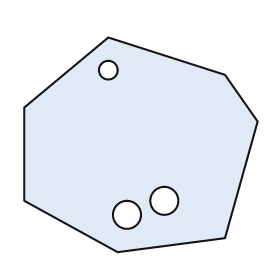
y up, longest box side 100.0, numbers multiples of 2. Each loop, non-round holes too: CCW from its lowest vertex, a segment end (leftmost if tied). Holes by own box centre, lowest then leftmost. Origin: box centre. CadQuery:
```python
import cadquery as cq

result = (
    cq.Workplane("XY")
    .moveTo(-10.0, -46.0)
    .lineTo(36.0, -40.0)
    .lineTo(50.0, 10.0)
    .lineTo(36.0, 30.0)
    .lineTo(-14.0, 46.0)
    .lineTo(-50.0, 16.0)
    .lineTo(-50.0, -24.0)
    .close()
    .moveTo(-6.0, -30.0)
    .circle(6.0)
    .moveTo(10.0, -24.0)
    .circle(6.0)
    .moveTo(-14.0, 32.0)
    .circle(4.0)
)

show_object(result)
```